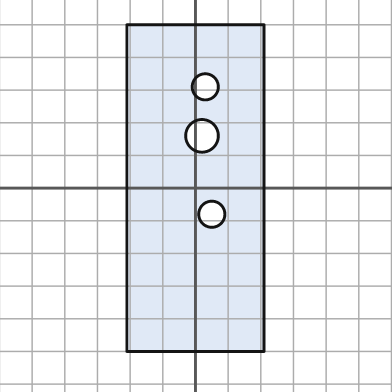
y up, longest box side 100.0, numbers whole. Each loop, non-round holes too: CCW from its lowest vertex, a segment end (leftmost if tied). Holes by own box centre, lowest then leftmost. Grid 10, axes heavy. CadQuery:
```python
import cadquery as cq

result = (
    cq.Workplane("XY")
    .moveTo(-21.0, -50.0)
    .lineTo(21.0, -50.0)
    .lineTo(21.0, 50.0)
    .lineTo(-21.0, 50.0)
    .close()
    .moveTo(5.0, -8.0)
    .circle(4.0)
    .moveTo(2.0, 16.0)
    .circle(5.0)
    .moveTo(3.0, 31.0)
    .circle(4.0)
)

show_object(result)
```